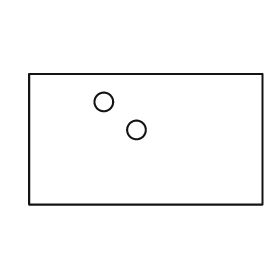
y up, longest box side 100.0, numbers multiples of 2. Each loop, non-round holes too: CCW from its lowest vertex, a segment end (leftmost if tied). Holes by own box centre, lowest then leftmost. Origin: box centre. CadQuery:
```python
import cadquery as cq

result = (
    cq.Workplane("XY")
    .moveTo(-50.0, -28.0)
    .lineTo(50.0, -28.0)
    .lineTo(50.0, 28.0)
    .lineTo(-50.0, 28.0)
    .close()
    .moveTo(-4.0, 4.0)
    .circle(4.0)
    .moveTo(-18.0, 16.0)
    .circle(4.0)
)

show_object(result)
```